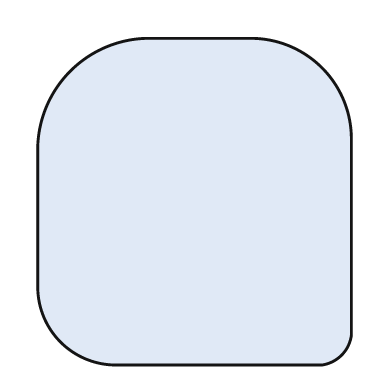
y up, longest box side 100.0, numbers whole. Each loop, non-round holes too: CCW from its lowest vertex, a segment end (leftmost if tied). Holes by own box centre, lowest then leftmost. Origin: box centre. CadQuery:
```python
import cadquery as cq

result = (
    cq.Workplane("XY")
    .moveTo(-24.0, -50.0)
    .lineTo(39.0, -50.0)
    .threePointArc((45.0, -47.0), (48.0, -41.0))
    .lineTo(48.0, 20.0)
    .threePointArc((39.0, 41.0), (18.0, 50.0))
    .lineTo(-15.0, 50.0)
    .threePointArc((-38.0, 40.0), (-48.0, 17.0))
    .lineTo(-48.0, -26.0)
    .threePointArc((-41.0, -43.0), (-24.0, -50.0))
    .close()
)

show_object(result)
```